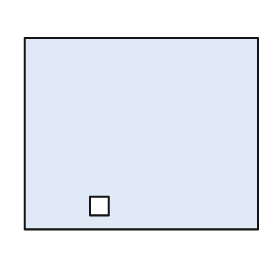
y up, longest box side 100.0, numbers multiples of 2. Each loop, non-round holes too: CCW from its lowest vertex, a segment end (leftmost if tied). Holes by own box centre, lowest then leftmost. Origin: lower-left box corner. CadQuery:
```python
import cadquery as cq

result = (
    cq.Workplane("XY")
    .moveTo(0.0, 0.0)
    .lineTo(100.0, 0.0)
    .lineTo(100.0, 82.0)
    .lineTo(0.0, 82.0)
    .close()
    .moveTo(28.0, 6.0)
    .lineTo(36.0, 6.0)
    .lineTo(36.0, 14.0)
    .lineTo(28.0, 14.0)
    .close()
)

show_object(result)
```